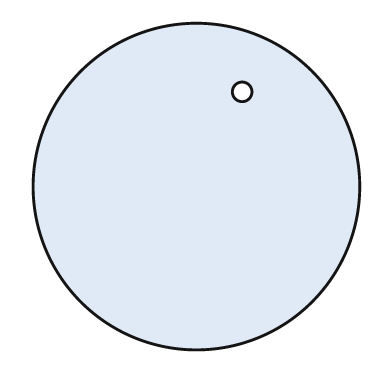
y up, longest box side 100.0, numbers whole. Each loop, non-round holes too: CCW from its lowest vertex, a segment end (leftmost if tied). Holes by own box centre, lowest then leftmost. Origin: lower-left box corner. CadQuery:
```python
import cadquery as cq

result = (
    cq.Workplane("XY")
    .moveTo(50.0, 50.0)
    .circle(50.0)
    .moveTo(64.0, 79.0)
    .circle(3.0)
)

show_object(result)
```